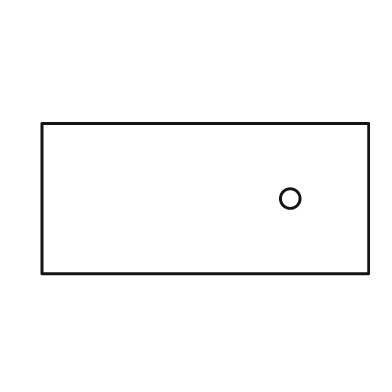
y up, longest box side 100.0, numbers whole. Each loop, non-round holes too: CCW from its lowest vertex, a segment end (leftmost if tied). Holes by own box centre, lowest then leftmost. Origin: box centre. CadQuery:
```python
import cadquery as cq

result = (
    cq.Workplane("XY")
    .moveTo(-50.0, -23.0)
    .lineTo(50.0, -23.0)
    .lineTo(50.0, 23.0)
    .lineTo(-50.0, 23.0)
    .close()
    .moveTo(26.0, 0.0)
    .circle(3.0)
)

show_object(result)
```